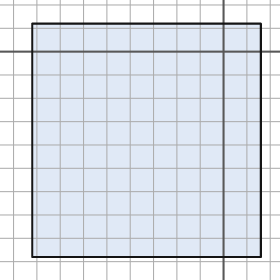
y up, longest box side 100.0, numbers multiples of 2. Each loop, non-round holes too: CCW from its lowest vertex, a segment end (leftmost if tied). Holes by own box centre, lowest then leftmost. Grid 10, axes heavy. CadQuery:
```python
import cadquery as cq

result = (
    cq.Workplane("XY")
    .moveTo(-82.0, -88.0)
    .lineTo(16.0, -88.0)
    .lineTo(16.0, 12.0)
    .lineTo(-82.0, 12.0)
    .close()
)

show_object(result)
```